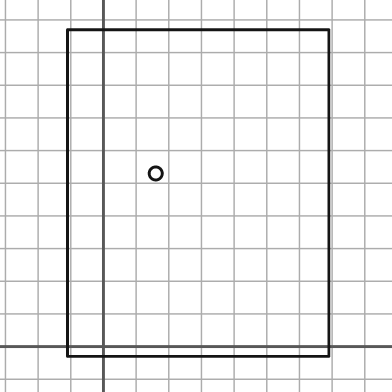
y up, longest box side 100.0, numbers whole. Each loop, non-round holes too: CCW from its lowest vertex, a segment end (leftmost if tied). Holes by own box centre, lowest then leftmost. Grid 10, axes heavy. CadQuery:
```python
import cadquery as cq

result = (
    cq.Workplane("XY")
    .moveTo(-11.0, -3.0)
    .lineTo(69.0, -3.0)
    .lineTo(69.0, 97.0)
    .lineTo(-11.0, 97.0)
    .close()
    .moveTo(16.0, 53.0)
    .circle(2.0)
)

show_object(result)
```